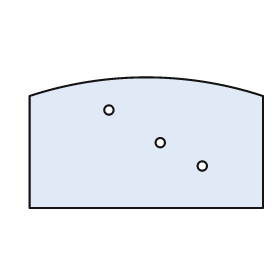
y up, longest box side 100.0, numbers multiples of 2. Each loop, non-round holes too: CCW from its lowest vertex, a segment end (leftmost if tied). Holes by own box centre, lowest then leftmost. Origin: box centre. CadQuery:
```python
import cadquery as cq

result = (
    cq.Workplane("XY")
    .moveTo(-50.0, -28.0)
    .lineTo(50.0, -28.0)
    .lineTo(50.0, 20.0)
    .threePointArc((0.0, 28.0), (-50.0, 20.0))
    .close()
    .moveTo(24.0, -10.0)
    .circle(2.0)
    .moveTo(6.0, 0.0)
    .circle(2.0)
    .moveTo(-16.0, 14.0)
    .circle(2.0)
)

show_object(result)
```